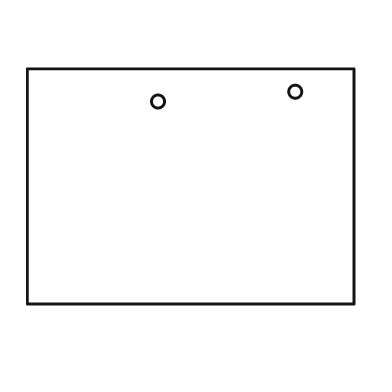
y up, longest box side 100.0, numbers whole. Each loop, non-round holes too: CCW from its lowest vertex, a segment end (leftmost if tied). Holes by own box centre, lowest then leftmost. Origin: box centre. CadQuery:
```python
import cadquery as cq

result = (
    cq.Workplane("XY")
    .moveTo(-50.0, -36.0)
    .lineTo(50.0, -36.0)
    .lineTo(50.0, 36.0)
    .lineTo(-50.0, 36.0)
    .close()
    .moveTo(-10.0, 26.0)
    .circle(2.0)
    .moveTo(32.0, 29.0)
    .circle(2.0)
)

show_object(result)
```